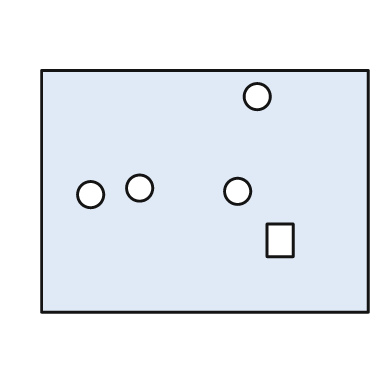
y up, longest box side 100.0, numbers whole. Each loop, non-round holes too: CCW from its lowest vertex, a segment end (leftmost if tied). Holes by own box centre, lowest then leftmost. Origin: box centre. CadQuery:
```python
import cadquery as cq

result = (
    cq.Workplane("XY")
    .moveTo(-50.0, -37.0)
    .lineTo(50.0, -37.0)
    .lineTo(50.0, 37.0)
    .lineTo(-50.0, 37.0)
    .close()
    .moveTo(19.0, -20.0)
    .lineTo(27.0, -20.0)
    .lineTo(27.0, -10.0)
    .lineTo(19.0, -10.0)
    .close()
    .moveTo(-35.0, -1.0)
    .circle(4.0)
    .moveTo(10.0, 0.0)
    .circle(4.0)
    .moveTo(-20.0, 1.0)
    .circle(4.0)
    .moveTo(16.0, 29.0)
    .circle(4.0)
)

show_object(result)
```